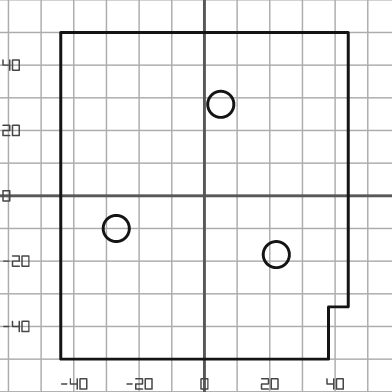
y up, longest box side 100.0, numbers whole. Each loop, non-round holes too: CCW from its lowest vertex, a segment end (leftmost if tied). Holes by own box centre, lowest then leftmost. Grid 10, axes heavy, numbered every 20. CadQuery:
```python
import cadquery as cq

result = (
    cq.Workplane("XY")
    .moveTo(-44.0, -50.0)
    .lineTo(38.0, -50.0)
    .lineTo(38.0, -34.0)
    .lineTo(44.0, -34.0)
    .lineTo(44.0, 50.0)
    .lineTo(-44.0, 50.0)
    .close()
    .moveTo(22.0, -18.0)
    .circle(4.0)
    .moveTo(-27.0, -10.0)
    .circle(4.0)
    .moveTo(5.0, 28.0)
    .circle(4.0)
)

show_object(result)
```